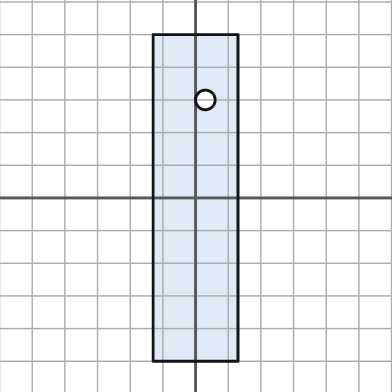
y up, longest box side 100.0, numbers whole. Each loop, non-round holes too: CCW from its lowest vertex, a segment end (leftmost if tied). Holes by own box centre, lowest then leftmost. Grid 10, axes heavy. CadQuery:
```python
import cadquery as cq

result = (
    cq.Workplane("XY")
    .moveTo(-13.0, -50.0)
    .lineTo(13.0, -50.0)
    .lineTo(13.0, 50.0)
    .lineTo(-13.0, 50.0)
    .close()
    .moveTo(3.0, 30.0)
    .circle(3.0)
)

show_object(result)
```